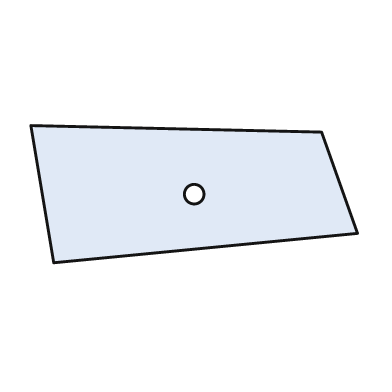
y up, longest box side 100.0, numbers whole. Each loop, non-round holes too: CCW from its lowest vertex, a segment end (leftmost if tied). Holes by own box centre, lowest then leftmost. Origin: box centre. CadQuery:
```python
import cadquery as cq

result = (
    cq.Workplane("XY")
    .moveTo(-43.0, -21.0)
    .lineTo(50.0, -12.0)
    .lineTo(39.0, 19.0)
    .lineTo(-50.0, 21.0)
    .close()
    .moveTo(0.0, 0.0)
    .circle(3.0)
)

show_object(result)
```